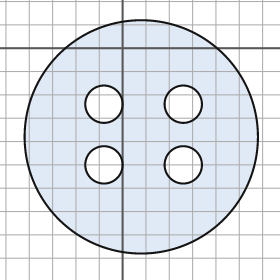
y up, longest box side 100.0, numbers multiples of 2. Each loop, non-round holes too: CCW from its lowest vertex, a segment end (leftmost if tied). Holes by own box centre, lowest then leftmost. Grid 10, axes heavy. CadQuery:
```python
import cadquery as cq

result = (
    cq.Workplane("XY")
    .moveTo(8.0, -38.0)
    .circle(50.0)
    .moveTo(-8.0, -50.0)
    .circle(8.0)
    .moveTo(26.0, -50.0)
    .circle(8.0)
    .moveTo(-8.0, -24.0)
    .circle(8.0)
    .moveTo(26.0, -24.0)
    .circle(8.0)
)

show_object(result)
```